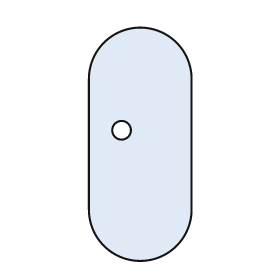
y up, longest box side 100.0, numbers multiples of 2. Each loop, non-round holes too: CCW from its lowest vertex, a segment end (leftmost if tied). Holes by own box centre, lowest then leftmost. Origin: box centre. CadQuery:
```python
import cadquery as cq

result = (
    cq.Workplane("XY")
    .moveTo(-22.0, -28.0)
    .threePointArc((0.0, -50.0), (22.0, -28.0))
    .lineTo(22.0, 28.0)
    .threePointArc((0.0, 50.0), (-22.0, 28.0))
    .close()
    .moveTo(-8.0, 6.0)
    .circle(4.0)
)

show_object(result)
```